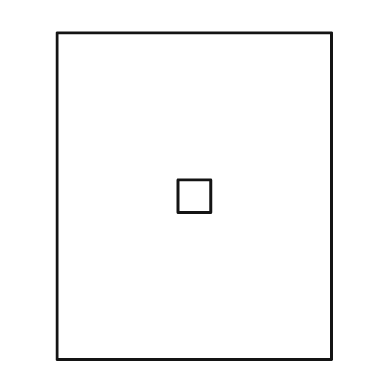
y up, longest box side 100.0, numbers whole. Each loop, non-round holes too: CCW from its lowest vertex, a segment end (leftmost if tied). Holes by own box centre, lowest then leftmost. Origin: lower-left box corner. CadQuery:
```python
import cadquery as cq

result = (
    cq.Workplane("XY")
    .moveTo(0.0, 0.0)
    .lineTo(84.0, 0.0)
    .lineTo(84.0, 100.0)
    .lineTo(0.0, 100.0)
    .close()
    .moveTo(37.0, 45.0)
    .lineTo(47.0, 45.0)
    .lineTo(47.0, 55.0)
    .lineTo(37.0, 55.0)
    .close()
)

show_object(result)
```